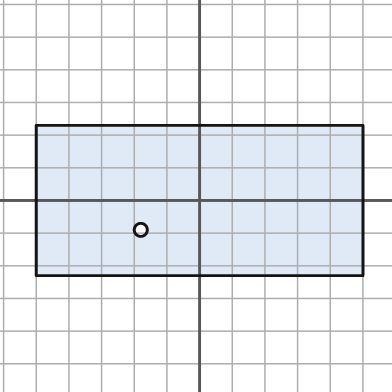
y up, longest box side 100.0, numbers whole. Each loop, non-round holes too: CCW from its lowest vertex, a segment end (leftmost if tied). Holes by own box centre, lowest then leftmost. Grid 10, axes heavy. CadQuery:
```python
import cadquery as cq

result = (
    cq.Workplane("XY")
    .moveTo(-50.0, -23.0)
    .lineTo(50.0, -23.0)
    .lineTo(50.0, 23.0)
    .lineTo(-50.0, 23.0)
    .close()
    .moveTo(-18.0, -9.0)
    .circle(2.0)
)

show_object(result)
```